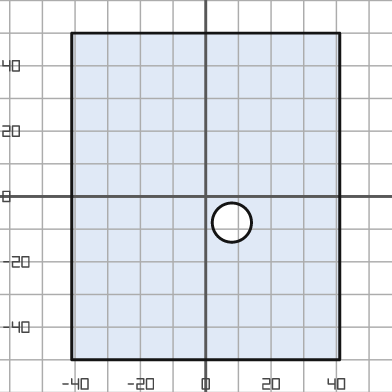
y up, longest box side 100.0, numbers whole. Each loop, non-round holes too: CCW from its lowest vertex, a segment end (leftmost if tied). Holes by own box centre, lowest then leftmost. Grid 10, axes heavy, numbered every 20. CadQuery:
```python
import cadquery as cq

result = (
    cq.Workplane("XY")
    .moveTo(-41.0, -50.0)
    .lineTo(41.0, -50.0)
    .lineTo(41.0, 50.0)
    .lineTo(-41.0, 50.0)
    .close()
    .moveTo(8.0, -8.0)
    .circle(6.0)
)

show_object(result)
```